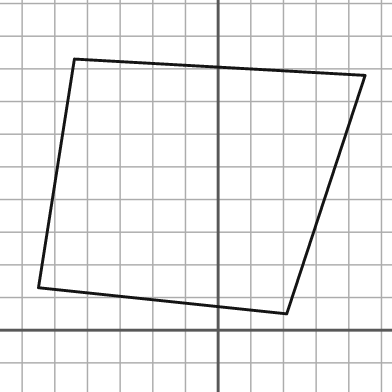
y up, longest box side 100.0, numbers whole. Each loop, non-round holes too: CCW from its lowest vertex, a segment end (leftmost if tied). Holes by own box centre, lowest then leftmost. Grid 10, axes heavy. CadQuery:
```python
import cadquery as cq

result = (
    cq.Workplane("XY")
    .moveTo(21.0, 5.0)
    .lineTo(45.0, 78.0)
    .lineTo(-44.0, 83.0)
    .lineTo(-55.0, 13.0)
    .close()
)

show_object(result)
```